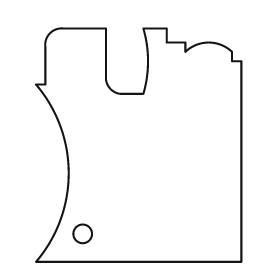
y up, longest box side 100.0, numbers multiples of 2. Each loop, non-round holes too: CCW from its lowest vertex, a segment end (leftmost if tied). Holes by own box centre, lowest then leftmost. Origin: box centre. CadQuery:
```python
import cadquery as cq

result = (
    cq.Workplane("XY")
    .moveTo(-44.0, -50.0)
    .lineTo(44.0, -50.0)
    .lineTo(44.0, 36.0)
    .lineTo(40.0, 36.0)
    .lineTo(40.0, 40.0)
    .threePointArc((30.0, 44.0), (20.0, 40.0))
    .lineTo(20.0, 44.0)
    .lineTo(12.0, 44.0)
    .lineTo(12.0, 50.0)
    .lineTo(2.0, 50.0)
    .threePointArc((4.0, 36.0), (2.0, 22.0))
    .lineTo(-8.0, 22.0)
    .threePointArc((-12.0, 24.0), (-14.0, 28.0))
    .lineTo(-14.0, 50.0)
    .lineTo(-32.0, 50.0)
    .threePointArc((-38.0, 48.0), (-40.0, 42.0))
    .lineTo(-40.0, 26.0)
    .lineTo(-44.0, 26.0)
    .threePointArc((-30.0, -12.0), (-44.0, -50.0))
    .close()
    .moveTo(-24.0, -38.0)
    .circle(4.0)
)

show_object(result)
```